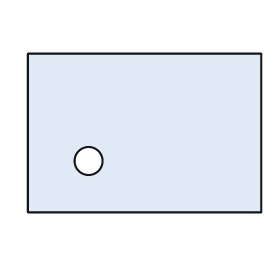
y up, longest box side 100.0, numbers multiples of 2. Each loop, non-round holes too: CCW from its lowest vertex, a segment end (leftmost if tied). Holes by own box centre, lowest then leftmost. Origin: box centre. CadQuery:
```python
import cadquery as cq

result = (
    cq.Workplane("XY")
    .moveTo(-50.0, -34.0)
    .lineTo(50.0, -34.0)
    .lineTo(50.0, 34.0)
    .lineTo(-50.0, 34.0)
    .close()
    .moveTo(-24.0, -12.0)
    .circle(6.0)
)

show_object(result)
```